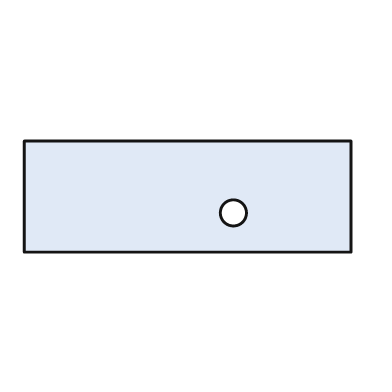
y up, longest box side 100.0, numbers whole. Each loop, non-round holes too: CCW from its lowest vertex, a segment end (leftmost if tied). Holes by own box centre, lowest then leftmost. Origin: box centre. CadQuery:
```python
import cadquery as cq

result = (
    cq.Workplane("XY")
    .moveTo(-50.0, -17.0)
    .lineTo(50.0, -17.0)
    .lineTo(50.0, 17.0)
    .lineTo(-50.0, 17.0)
    .close()
    .moveTo(14.0, -5.0)
    .circle(4.0)
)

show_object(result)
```